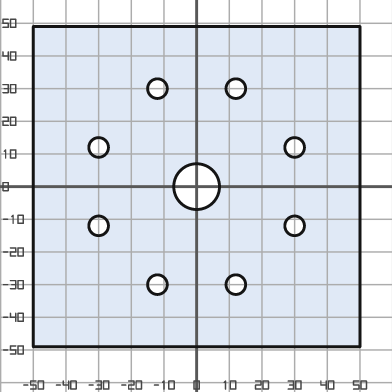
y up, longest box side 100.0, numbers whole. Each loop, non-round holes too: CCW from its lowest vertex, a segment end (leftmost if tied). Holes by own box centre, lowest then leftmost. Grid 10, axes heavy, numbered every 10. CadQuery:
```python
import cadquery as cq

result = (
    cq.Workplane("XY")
    .moveTo(-50.0, -49.0)
    .lineTo(50.0, -49.0)
    .lineTo(50.0, 49.0)
    .lineTo(-50.0, 49.0)
    .close()
    .moveTo(-12.0, -30.0)
    .circle(3.0)
    .moveTo(12.0, -30.0)
    .circle(3.0)
    .moveTo(-30.0, -12.0)
    .circle(3.0)
    .moveTo(30.0, -12.0)
    .circle(3.0)
    .moveTo(0.0, 0.0)
    .circle(7.0)
    .moveTo(-30.0, 12.0)
    .circle(3.0)
    .moveTo(30.0, 12.0)
    .circle(3.0)
    .moveTo(-12.0, 30.0)
    .circle(3.0)
    .moveTo(12.0, 30.0)
    .circle(3.0)
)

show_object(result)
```